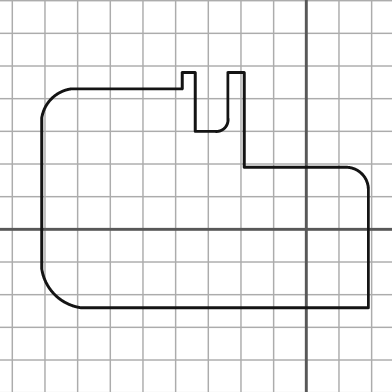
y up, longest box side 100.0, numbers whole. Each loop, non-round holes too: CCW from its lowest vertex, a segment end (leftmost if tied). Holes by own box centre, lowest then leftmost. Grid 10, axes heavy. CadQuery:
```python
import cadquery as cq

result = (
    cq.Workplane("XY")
    .moveTo(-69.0, -24.0)
    .lineTo(19.0, -24.0)
    .lineTo(19.0, 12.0)
    .threePointArc((17.0, 17.0), (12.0, 19.0))
    .lineTo(-19.0, 19.0)
    .lineTo(-19.0, 48.0)
    .lineTo(-24.0, 48.0)
    .lineTo(-24.0, 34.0)
    .threePointArc((-25.0, 31.0), (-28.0, 30.0))
    .lineTo(-34.0, 30.0)
    .lineTo(-34.0, 48.0)
    .lineTo(-38.0, 48.0)
    .lineTo(-38.0, 43.0)
    .lineTo(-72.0, 43.0)
    .threePointArc((-78.0, 40.0), (-81.0, 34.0))
    .lineTo(-81.0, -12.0)
    .threePointArc((-77.0, -20.0), (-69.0, -24.0))
    .close()
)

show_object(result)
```